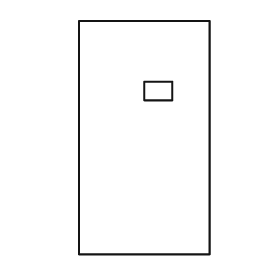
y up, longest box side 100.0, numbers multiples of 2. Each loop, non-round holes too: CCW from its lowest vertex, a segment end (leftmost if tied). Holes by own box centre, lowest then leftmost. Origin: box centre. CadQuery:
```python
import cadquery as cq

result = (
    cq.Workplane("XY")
    .moveTo(-28.0, -50.0)
    .lineTo(28.0, -50.0)
    .lineTo(28.0, 50.0)
    .lineTo(-28.0, 50.0)
    .close()
    .moveTo(0.0, 16.0)
    .lineTo(12.0, 16.0)
    .lineTo(12.0, 24.0)
    .lineTo(0.0, 24.0)
    .close()
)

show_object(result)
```